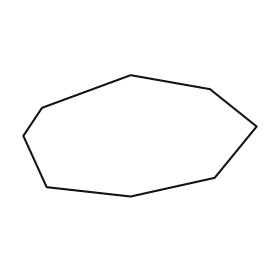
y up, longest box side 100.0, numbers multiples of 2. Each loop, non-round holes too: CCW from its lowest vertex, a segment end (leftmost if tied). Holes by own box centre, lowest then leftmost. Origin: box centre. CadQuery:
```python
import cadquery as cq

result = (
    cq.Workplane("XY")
    .moveTo(-4.0, -26.0)
    .lineTo(32.0, -18.0)
    .lineTo(50.0, 4.0)
    .lineTo(30.0, 20.0)
    .lineTo(-4.0, 26.0)
    .lineTo(-42.0, 12.0)
    .lineTo(-50.0, 0.0)
    .lineTo(-40.0, -22.0)
    .close()
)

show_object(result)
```